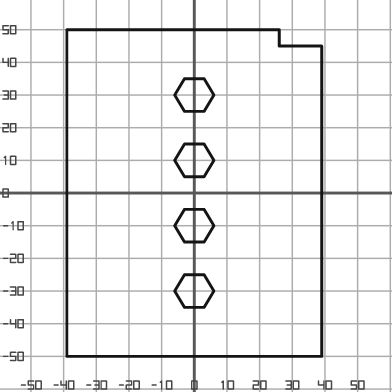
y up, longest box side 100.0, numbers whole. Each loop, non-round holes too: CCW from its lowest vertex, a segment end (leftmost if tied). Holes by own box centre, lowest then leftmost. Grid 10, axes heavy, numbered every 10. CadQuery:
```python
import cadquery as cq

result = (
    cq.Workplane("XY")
    .moveTo(-39.0, -50.0)
    .lineTo(39.0, -50.0)
    .lineTo(39.0, 45.0)
    .lineTo(26.0, 45.0)
    .lineTo(26.0, 50.0)
    .lineTo(-39.0, 50.0)
    .close()
    .moveTo(-3.0, -35.0)
    .lineTo(3.0, -35.0)
    .lineTo(6.0, -30.0)
    .lineTo(3.0, -25.0)
    .lineTo(-3.0, -25.0)
    .lineTo(-6.0, -30.0)
    .close()
    .moveTo(-3.0, -15.0)
    .lineTo(3.0, -15.0)
    .lineTo(6.0, -10.0)
    .lineTo(3.0, -5.0)
    .lineTo(-3.0, -5.0)
    .lineTo(-6.0, -10.0)
    .close()
    .moveTo(-3.0, 5.0)
    .lineTo(3.0, 5.0)
    .lineTo(6.0, 10.0)
    .lineTo(3.0, 15.0)
    .lineTo(-3.0, 15.0)
    .lineTo(-6.0, 10.0)
    .close()
    .moveTo(-3.0, 25.0)
    .lineTo(3.0, 25.0)
    .lineTo(6.0, 30.0)
    .lineTo(3.0, 35.0)
    .lineTo(-3.0, 35.0)
    .lineTo(-6.0, 30.0)
    .close()
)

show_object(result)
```